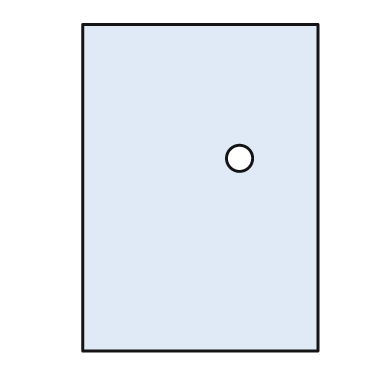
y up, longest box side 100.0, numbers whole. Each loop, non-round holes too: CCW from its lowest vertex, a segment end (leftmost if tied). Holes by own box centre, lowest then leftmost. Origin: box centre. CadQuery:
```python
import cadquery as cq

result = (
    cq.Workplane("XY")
    .moveTo(-36.0, -50.0)
    .lineTo(36.0, -50.0)
    .lineTo(36.0, 50.0)
    .lineTo(-36.0, 50.0)
    .close()
    .moveTo(12.0, 9.0)
    .circle(4.0)
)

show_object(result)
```